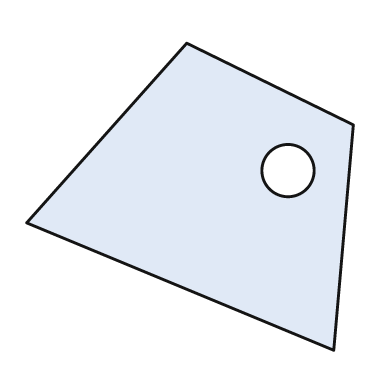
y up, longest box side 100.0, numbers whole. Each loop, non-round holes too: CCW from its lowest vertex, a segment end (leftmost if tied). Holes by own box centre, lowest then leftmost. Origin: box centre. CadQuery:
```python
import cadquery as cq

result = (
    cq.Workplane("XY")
    .moveTo(44.0, -47.0)
    .lineTo(50.0, 22.0)
    .lineTo(-1.0, 47.0)
    .lineTo(-50.0, -8.0)
    .close()
    .moveTo(30.0, 8.0)
    .circle(8.0)
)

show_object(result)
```